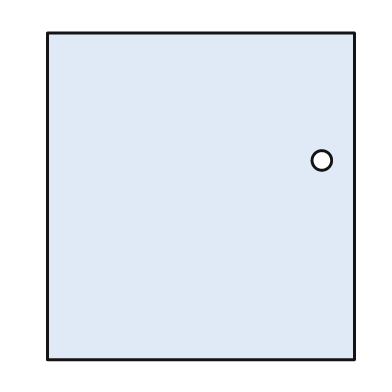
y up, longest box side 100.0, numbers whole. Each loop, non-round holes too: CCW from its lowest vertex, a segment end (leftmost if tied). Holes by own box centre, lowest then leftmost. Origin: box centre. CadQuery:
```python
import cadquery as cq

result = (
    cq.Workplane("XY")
    .moveTo(-47.0, -50.0)
    .lineTo(47.0, -50.0)
    .lineTo(47.0, 50.0)
    .lineTo(-47.0, 50.0)
    .close()
    .moveTo(37.0, 11.0)
    .circle(3.0)
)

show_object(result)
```